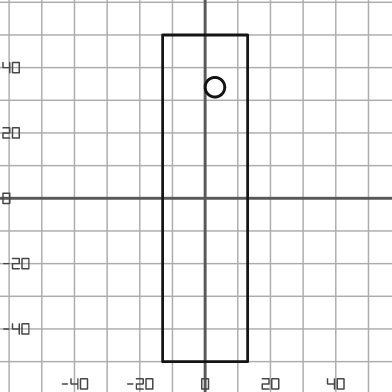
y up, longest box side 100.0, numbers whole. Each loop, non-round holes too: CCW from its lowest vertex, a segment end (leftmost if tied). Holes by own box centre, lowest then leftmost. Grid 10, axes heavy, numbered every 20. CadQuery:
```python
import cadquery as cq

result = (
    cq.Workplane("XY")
    .moveTo(-13.0, -50.0)
    .lineTo(13.0, -50.0)
    .lineTo(13.0, 50.0)
    .lineTo(-13.0, 50.0)
    .close()
    .moveTo(3.0, 34.0)
    .circle(3.0)
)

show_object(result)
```